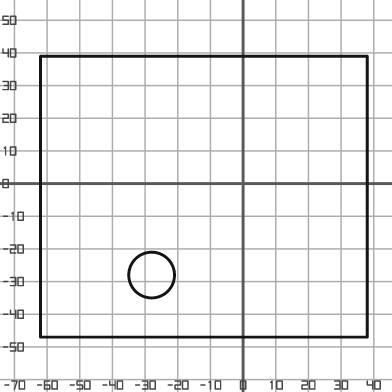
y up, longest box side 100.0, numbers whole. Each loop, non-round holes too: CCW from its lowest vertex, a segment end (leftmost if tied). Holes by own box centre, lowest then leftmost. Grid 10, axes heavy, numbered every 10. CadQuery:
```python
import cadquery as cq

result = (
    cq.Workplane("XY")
    .moveTo(-62.0, -47.0)
    .lineTo(38.0, -47.0)
    .lineTo(38.0, 39.0)
    .lineTo(-62.0, 39.0)
    .close()
    .moveTo(-28.0, -28.0)
    .circle(7.0)
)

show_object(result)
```